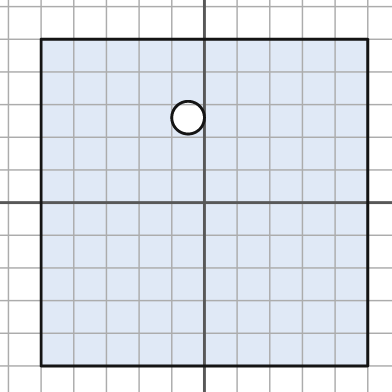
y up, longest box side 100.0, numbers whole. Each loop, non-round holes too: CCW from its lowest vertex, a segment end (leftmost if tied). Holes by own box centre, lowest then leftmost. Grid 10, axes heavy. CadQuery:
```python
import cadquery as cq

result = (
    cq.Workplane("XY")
    .moveTo(-50.0, -50.0)
    .lineTo(50.0, -50.0)
    .lineTo(50.0, 50.0)
    .lineTo(-50.0, 50.0)
    .close()
    .moveTo(-5.0, 26.0)
    .circle(5.0)
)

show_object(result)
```